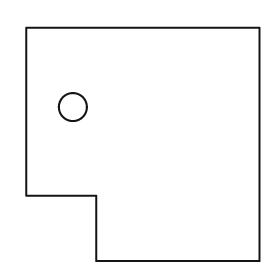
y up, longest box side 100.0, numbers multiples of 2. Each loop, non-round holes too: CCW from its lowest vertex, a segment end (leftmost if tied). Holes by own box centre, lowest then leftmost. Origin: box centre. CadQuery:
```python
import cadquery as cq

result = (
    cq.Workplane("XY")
    .moveTo(-20.0, -50.0)
    .lineTo(50.0, -50.0)
    .lineTo(50.0, 50.0)
    .lineTo(-50.0, 50.0)
    .lineTo(-50.0, -22.0)
    .lineTo(-20.0, -22.0)
    .close()
    .moveTo(-30.0, 16.0)
    .circle(6.0)
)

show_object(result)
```